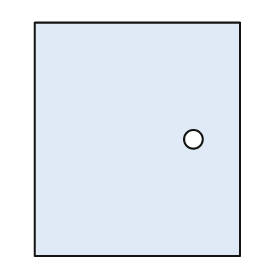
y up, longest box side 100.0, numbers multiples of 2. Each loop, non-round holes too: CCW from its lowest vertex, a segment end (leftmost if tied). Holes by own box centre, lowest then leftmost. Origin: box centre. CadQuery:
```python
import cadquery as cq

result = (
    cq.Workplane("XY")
    .moveTo(-44.0, -50.0)
    .lineTo(44.0, -50.0)
    .lineTo(44.0, 50.0)
    .lineTo(-44.0, 50.0)
    .close()
    .moveTo(24.0, 0.0)
    .circle(4.0)
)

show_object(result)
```